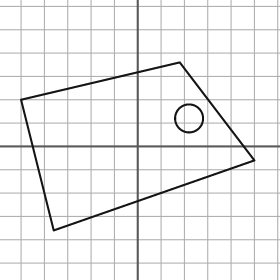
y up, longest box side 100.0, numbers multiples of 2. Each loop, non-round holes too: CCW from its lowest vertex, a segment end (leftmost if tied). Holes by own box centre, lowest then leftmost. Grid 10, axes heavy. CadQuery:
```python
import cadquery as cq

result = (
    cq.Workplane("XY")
    .moveTo(-36.0, -36.0)
    .lineTo(50.0, -6.0)
    .lineTo(18.0, 36.0)
    .lineTo(-50.0, 20.0)
    .close()
    .moveTo(22.0, 12.0)
    .circle(6.0)
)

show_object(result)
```